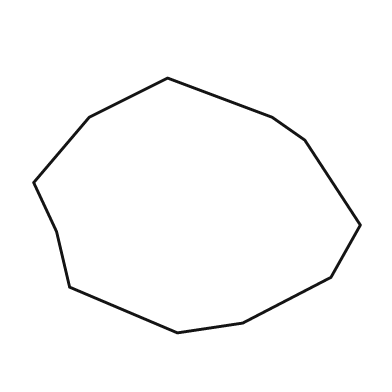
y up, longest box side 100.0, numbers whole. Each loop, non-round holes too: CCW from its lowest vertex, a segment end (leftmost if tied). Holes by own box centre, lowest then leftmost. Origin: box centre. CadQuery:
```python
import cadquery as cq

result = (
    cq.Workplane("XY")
    .moveTo(-6.0, -39.0)
    .lineTo(14.0, -36.0)
    .lineTo(41.0, -22.0)
    .lineTo(50.0, -6.0)
    .lineTo(33.0, 20.0)
    .lineTo(23.0, 27.0)
    .lineTo(-9.0, 39.0)
    .lineTo(-33.0, 27.0)
    .lineTo(-50.0, 7.0)
    .lineTo(-43.0, -8.0)
    .lineTo(-39.0, -25.0)
    .close()
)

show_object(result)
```